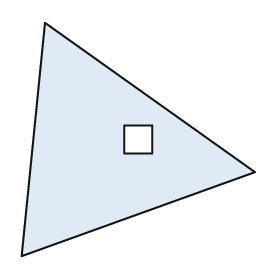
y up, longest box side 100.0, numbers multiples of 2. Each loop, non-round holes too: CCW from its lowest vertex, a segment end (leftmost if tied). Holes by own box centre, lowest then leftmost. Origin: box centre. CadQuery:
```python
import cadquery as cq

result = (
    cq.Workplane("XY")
    .moveTo(-50.0, -50.0)
    .lineTo(50.0, -14.0)
    .lineTo(-40.0, 50.0)
    .close()
    .moveTo(-6.0, -6.0)
    .lineTo(6.0, -6.0)
    .lineTo(6.0, 6.0)
    .lineTo(-6.0, 6.0)
    .close()
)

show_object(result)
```